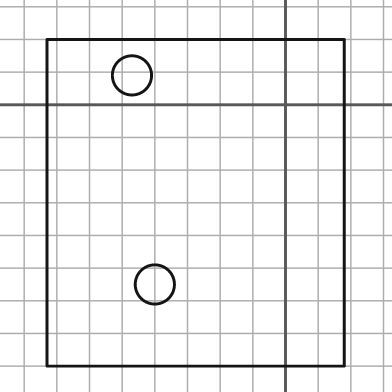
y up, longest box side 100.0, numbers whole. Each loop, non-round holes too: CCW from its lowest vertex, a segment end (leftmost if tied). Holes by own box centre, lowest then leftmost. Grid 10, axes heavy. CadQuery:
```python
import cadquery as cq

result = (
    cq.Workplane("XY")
    .moveTo(-73.0, -80.0)
    .lineTo(18.0, -80.0)
    .lineTo(18.0, 20.0)
    .lineTo(-73.0, 20.0)
    .close()
    .moveTo(-40.0, -55.0)
    .circle(6.0)
    .moveTo(-47.0, 9.0)
    .circle(6.0)
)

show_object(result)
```